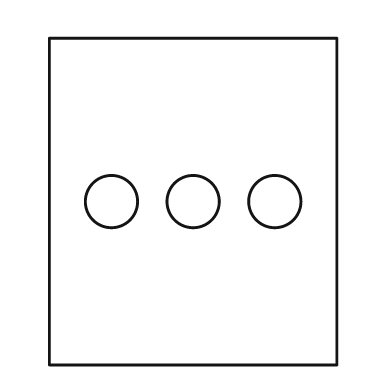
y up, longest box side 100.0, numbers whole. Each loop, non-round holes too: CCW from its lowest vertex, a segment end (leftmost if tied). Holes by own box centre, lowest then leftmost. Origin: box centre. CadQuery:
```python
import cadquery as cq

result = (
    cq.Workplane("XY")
    .moveTo(-44.0, -50.0)
    .lineTo(44.0, -50.0)
    .lineTo(44.0, 50.0)
    .lineTo(-44.0, 50.0)
    .close()
    .moveTo(-25.0, 0.0)
    .circle(8.0)
    .moveTo(0.0, 0.0)
    .circle(8.0)
    .moveTo(25.0, 0.0)
    .circle(8.0)
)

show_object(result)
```